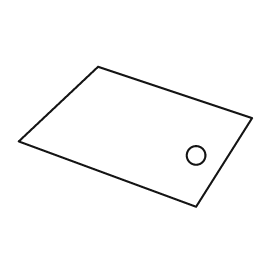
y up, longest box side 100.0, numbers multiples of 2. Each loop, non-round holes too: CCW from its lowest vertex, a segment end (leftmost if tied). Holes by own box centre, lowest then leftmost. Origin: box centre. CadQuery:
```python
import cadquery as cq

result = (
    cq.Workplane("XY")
    .moveTo(26.0, -30.0)
    .lineTo(50.0, 8.0)
    .lineTo(-16.0, 30.0)
    .lineTo(-50.0, -2.0)
    .close()
    .moveTo(26.0, -8.0)
    .circle(4.0)
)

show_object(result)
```